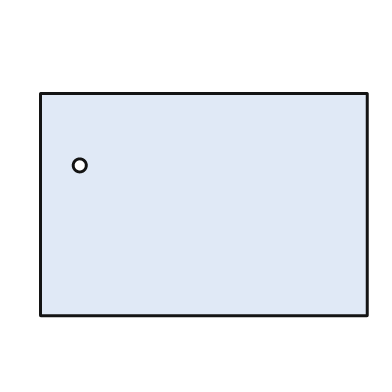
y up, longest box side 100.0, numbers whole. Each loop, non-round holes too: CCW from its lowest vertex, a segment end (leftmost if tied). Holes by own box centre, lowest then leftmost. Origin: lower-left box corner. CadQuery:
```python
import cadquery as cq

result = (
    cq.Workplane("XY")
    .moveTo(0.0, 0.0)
    .lineTo(100.0, 0.0)
    .lineTo(100.0, 68.0)
    .lineTo(0.0, 68.0)
    .close()
    .moveTo(12.0, 46.0)
    .circle(2.0)
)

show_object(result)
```